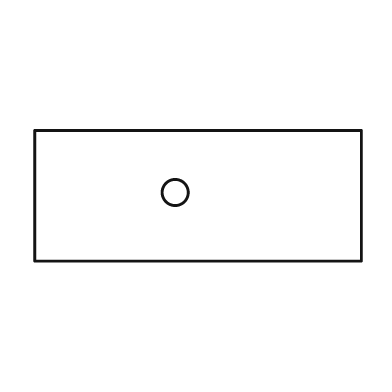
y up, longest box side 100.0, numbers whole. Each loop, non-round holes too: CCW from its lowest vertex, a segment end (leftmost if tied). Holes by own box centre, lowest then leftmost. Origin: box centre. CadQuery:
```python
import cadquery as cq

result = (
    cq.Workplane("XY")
    .moveTo(-50.0, -20.0)
    .lineTo(50.0, -20.0)
    .lineTo(50.0, 20.0)
    .lineTo(-50.0, 20.0)
    .close()
    .moveTo(-7.0, 1.0)
    .circle(4.0)
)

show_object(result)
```